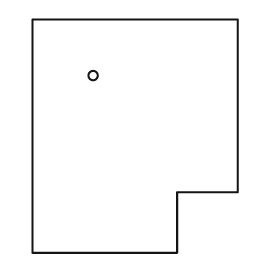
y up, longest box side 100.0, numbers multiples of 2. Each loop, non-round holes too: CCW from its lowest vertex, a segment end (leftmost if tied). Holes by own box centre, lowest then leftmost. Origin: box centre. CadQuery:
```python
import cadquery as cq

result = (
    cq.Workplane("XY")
    .moveTo(-44.0, -50.0)
    .lineTo(18.0, -50.0)
    .lineTo(18.0, -24.0)
    .lineTo(44.0, -24.0)
    .lineTo(44.0, 50.0)
    .lineTo(-44.0, 50.0)
    .close()
    .moveTo(-18.0, 26.0)
    .circle(2.0)
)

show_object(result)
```